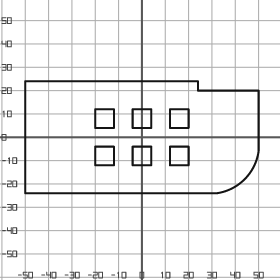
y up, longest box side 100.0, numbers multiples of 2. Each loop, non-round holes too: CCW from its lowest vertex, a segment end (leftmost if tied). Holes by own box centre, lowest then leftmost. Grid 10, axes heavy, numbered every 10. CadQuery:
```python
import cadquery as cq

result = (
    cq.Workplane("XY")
    .moveTo(-50.0, -24.0)
    .lineTo(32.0, -24.0)
    .threePointArc((44.0, -18.0), (50.0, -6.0))
    .lineTo(50.0, 20.0)
    .lineTo(24.0, 20.0)
    .lineTo(24.0, 24.0)
    .lineTo(-50.0, 24.0)
    .close()
    .moveTo(-20.0, -12.0)
    .lineTo(-12.0, -12.0)
    .lineTo(-12.0, -4.0)
    .lineTo(-20.0, -4.0)
    .close()
    .moveTo(-4.0, -12.0)
    .lineTo(4.0, -12.0)
    .lineTo(4.0, -4.0)
    .lineTo(-4.0, -4.0)
    .close()
    .moveTo(12.0, -12.0)
    .lineTo(20.0, -12.0)
    .lineTo(20.0, -4.0)
    .lineTo(12.0, -4.0)
    .close()
    .moveTo(-20.0, 4.0)
    .lineTo(-12.0, 4.0)
    .lineTo(-12.0, 12.0)
    .lineTo(-20.0, 12.0)
    .close()
    .moveTo(-4.0, 4.0)
    .lineTo(4.0, 4.0)
    .lineTo(4.0, 12.0)
    .lineTo(-4.0, 12.0)
    .close()
    .moveTo(12.0, 4.0)
    .lineTo(20.0, 4.0)
    .lineTo(20.0, 12.0)
    .lineTo(12.0, 12.0)
    .close()
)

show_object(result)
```